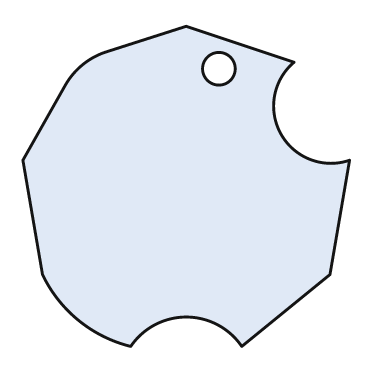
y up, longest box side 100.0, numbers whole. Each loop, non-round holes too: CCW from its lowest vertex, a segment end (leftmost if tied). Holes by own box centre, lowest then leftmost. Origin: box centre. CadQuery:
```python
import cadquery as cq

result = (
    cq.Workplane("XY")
    .moveTo(-17.0, -49.0)
    .threePointArc((0.0, -40.0), (17.0, -49.0))
    .lineTo(44.0, -27.0)
    .lineTo(50.0, 8.0)
    .threePointArc((29.0, 16.0), (33.0, 38.0))
    .lineTo(0.0, 49.0)
    .lineTo(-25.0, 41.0)
    .threePointArc((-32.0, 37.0), (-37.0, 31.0))
    .lineTo(-50.0, 8.0)
    .lineTo(-44.0, -27.0)
    .threePointArc((-33.0, -41.0), (-17.0, -49.0))
    .close()
    .moveTo(10.0, 36.0)
    .circle(5.0)
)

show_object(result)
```